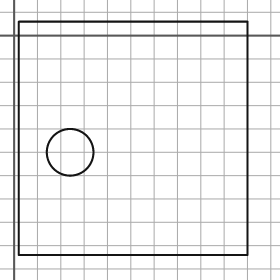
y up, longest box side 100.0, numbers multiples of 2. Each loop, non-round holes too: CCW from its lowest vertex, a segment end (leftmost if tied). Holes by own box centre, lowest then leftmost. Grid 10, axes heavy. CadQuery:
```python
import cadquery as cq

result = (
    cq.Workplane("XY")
    .moveTo(2.0, -94.0)
    .lineTo(100.0, -94.0)
    .lineTo(100.0, 6.0)
    .lineTo(2.0, 6.0)
    .close()
    .moveTo(24.0, -50.0)
    .circle(10.0)
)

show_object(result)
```